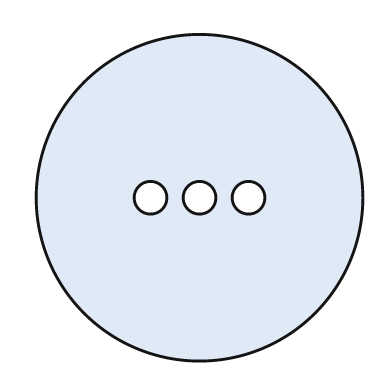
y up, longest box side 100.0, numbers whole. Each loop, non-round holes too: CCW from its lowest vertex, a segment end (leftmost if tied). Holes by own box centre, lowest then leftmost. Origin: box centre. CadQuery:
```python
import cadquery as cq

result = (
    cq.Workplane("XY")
    .moveTo(0.0, 0.0)
    .circle(50.0)
    .moveTo(-15.0, 0.0)
    .circle(5.0)
    .moveTo(0.0, 0.0)
    .circle(5.0)
    .moveTo(15.0, 0.0)
    .circle(5.0)
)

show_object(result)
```